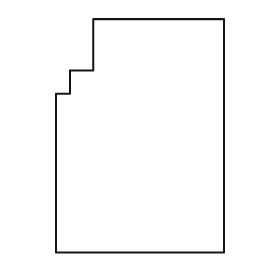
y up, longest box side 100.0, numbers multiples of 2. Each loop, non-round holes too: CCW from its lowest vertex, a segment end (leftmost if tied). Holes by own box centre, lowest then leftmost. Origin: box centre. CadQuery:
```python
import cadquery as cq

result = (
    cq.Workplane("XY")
    .moveTo(-36.0, -50.0)
    .lineTo(36.0, -50.0)
    .lineTo(36.0, 50.0)
    .lineTo(-20.0, 50.0)
    .lineTo(-20.0, 28.0)
    .lineTo(-30.0, 28.0)
    .lineTo(-30.0, 18.0)
    .lineTo(-36.0, 18.0)
    .close()
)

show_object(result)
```